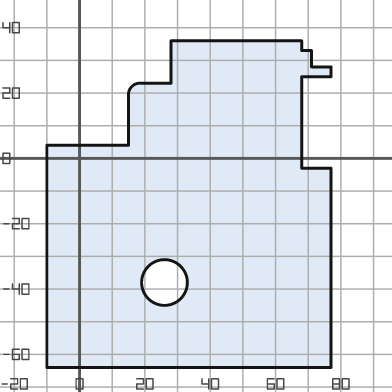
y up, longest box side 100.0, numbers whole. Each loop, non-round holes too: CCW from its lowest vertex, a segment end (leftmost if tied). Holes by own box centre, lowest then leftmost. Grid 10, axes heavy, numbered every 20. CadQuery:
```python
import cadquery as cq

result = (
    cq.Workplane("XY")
    .moveTo(-10.0, -64.0)
    .lineTo(77.0, -64.0)
    .lineTo(77.0, -3.0)
    .lineTo(68.0, -3.0)
    .lineTo(68.0, 25.0)
    .lineTo(77.0, 25.0)
    .lineTo(77.0, 28.0)
    .lineTo(71.0, 28.0)
    .lineTo(71.0, 33.0)
    .lineTo(68.0, 33.0)
    .lineTo(68.0, 36.0)
    .lineTo(28.0, 36.0)
    .lineTo(28.0, 23.0)
    .lineTo(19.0, 23.0)
    .threePointArc((16.0, 22.0), (15.0, 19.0))
    .lineTo(15.0, 4.0)
    .lineTo(-10.0, 4.0)
    .close()
    .moveTo(26.0, -38.0)
    .circle(7.0)
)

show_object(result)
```